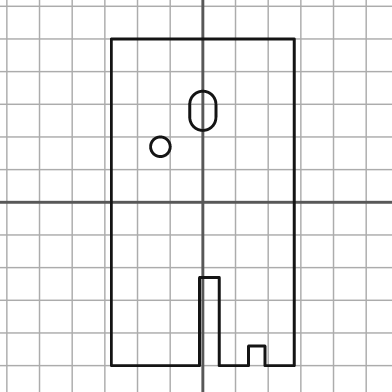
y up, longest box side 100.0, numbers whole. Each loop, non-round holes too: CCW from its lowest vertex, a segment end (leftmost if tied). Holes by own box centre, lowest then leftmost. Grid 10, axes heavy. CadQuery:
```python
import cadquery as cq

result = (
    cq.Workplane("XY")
    .moveTo(-28.0, -50.0)
    .lineTo(-1.0, -50.0)
    .lineTo(-1.0, -23.0)
    .lineTo(5.0, -23.0)
    .lineTo(5.0, -50.0)
    .lineTo(14.0, -50.0)
    .lineTo(14.0, -44.0)
    .lineTo(19.0, -44.0)
    .lineTo(19.0, -50.0)
    .lineTo(28.0, -50.0)
    .lineTo(28.0, 50.0)
    .lineTo(-28.0, 50.0)
    .close()
    .moveTo(-13.0, 17.0)
    .circle(3.0)
    .moveTo(-4.0, 26.0)
    .threePointArc((0.0, 22.0), (4.0, 26.0))
    .lineTo(4.0, 30.0)
    .threePointArc((0.0, 34.0), (-4.0, 30.0))
    .close()
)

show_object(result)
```